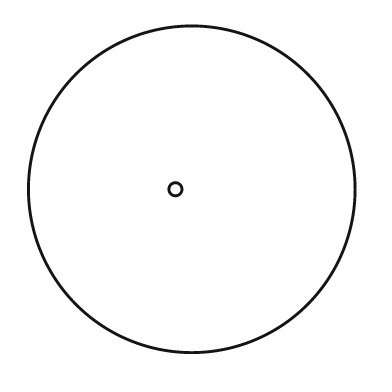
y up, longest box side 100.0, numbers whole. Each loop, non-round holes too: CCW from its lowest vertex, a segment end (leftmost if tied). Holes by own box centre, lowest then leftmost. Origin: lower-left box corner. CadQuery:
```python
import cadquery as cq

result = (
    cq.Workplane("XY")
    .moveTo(50.0, 50.0)
    .circle(50.0)
    .moveTo(45.0, 50.0)
    .circle(2.0)
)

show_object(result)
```